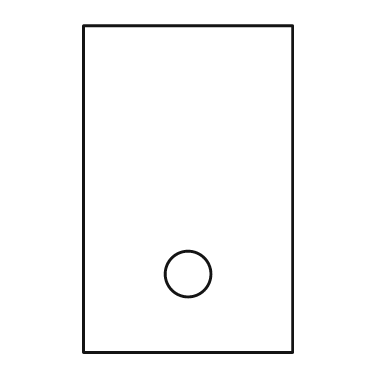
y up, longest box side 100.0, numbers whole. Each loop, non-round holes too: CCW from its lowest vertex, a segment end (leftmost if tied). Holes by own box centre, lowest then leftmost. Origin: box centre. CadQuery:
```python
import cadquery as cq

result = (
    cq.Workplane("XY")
    .moveTo(-32.0, -50.0)
    .lineTo(32.0, -50.0)
    .lineTo(32.0, 50.0)
    .lineTo(-32.0, 50.0)
    .close()
    .moveTo(0.0, -26.0)
    .circle(7.0)
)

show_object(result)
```